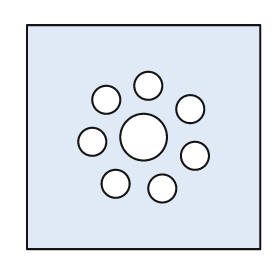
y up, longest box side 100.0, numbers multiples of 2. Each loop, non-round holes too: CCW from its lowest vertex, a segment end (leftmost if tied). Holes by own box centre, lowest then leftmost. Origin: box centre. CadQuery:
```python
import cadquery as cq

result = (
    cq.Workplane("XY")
    .moveTo(-50.0, -48.0)
    .lineTo(50.0, -48.0)
    .lineTo(50.0, 48.0)
    .lineTo(-50.0, 48.0)
    .close()
    .moveTo(8.0, -22.0)
    .circle(6.0)
    .moveTo(-12.0, -20.0)
    .circle(6.0)
    .moveTo(22.0, -8.0)
    .circle(6.0)
    .moveTo(-22.0, -2.0)
    .circle(6.0)
    .moveTo(0.0, 0.0)
    .circle(10.0)
    .moveTo(20.0, 12.0)
    .circle(6.0)
    .moveTo(-16.0, 16.0)
    .circle(6.0)
    .moveTo(2.0, 22.0)
    .circle(6.0)
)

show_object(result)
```